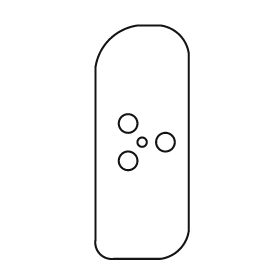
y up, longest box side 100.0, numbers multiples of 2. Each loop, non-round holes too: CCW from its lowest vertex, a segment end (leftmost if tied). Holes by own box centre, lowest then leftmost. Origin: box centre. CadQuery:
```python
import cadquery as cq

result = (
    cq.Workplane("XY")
    .moveTo(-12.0, -50.0)
    .lineTo(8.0, -50.0)
    .threePointArc((16.0, -46.0), (20.0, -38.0))
    .lineTo(20.0, 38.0)
    .threePointArc((16.0, 46.0), (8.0, 50.0))
    .lineTo(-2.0, 50.0)
    .threePointArc((-14.0, 44.0), (-20.0, 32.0))
    .lineTo(-20.0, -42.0)
    .threePointArc((-18.0, -48.0), (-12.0, -50.0))
    .close()
    .moveTo(-6.0, -8.0)
    .circle(4.0)
    .moveTo(0.0, 0.0)
    .circle(2.0)
    .moveTo(10.0, 0.0)
    .circle(4.0)
    .moveTo(-6.0, 8.0)
    .circle(4.0)
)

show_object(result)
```